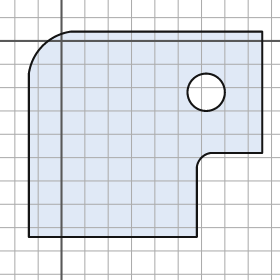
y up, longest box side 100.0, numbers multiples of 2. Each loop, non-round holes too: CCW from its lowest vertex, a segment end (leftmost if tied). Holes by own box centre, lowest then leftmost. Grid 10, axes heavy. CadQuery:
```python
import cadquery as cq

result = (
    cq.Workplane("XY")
    .moveTo(-14.0, -84.0)
    .lineTo(58.0, -84.0)
    .lineTo(58.0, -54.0)
    .threePointArc((60.0, -50.0), (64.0, -48.0))
    .lineTo(86.0, -48.0)
    .lineTo(86.0, 4.0)
    .lineTo(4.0, 4.0)
    .threePointArc((-8.0, -2.0), (-14.0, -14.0))
    .close()
    .moveTo(62.0, -22.0)
    .circle(8.0)
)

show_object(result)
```